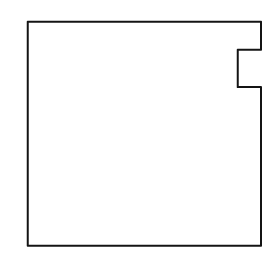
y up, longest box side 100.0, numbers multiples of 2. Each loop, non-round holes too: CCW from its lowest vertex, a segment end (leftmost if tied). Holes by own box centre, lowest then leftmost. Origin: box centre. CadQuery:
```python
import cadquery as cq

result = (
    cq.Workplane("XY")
    .moveTo(-50.0, -48.0)
    .lineTo(50.0, -48.0)
    .lineTo(50.0, 20.0)
    .lineTo(40.0, 20.0)
    .lineTo(40.0, 36.0)
    .lineTo(50.0, 36.0)
    .lineTo(50.0, 48.0)
    .lineTo(-50.0, 48.0)
    .close()
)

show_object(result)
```